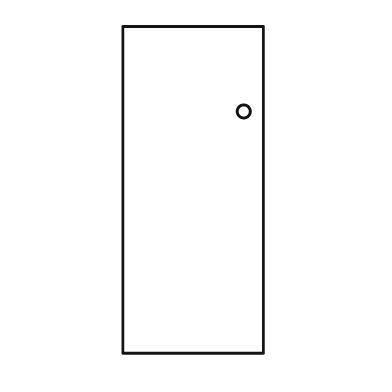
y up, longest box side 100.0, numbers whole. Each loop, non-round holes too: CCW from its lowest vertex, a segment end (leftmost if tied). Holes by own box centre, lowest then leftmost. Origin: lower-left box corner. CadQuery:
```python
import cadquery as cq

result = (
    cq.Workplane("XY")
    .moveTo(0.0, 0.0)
    .lineTo(43.0, 0.0)
    .lineTo(43.0, 100.0)
    .lineTo(0.0, 100.0)
    .close()
    .moveTo(37.0, 74.0)
    .circle(2.0)
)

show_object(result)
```